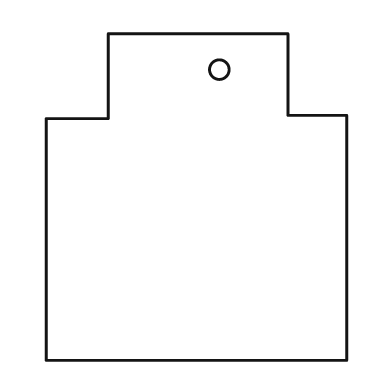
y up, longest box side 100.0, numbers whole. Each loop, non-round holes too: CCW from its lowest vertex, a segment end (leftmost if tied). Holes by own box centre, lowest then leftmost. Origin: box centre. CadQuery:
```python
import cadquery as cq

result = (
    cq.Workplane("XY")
    .moveTo(-46.0, -50.0)
    .lineTo(46.0, -50.0)
    .lineTo(46.0, 25.0)
    .lineTo(28.0, 25.0)
    .lineTo(28.0, 50.0)
    .lineTo(-27.0, 50.0)
    .lineTo(-27.0, 24.0)
    .lineTo(-46.0, 24.0)
    .close()
    .moveTo(7.0, 39.0)
    .circle(3.0)
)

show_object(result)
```